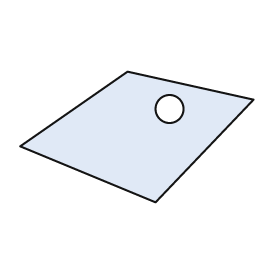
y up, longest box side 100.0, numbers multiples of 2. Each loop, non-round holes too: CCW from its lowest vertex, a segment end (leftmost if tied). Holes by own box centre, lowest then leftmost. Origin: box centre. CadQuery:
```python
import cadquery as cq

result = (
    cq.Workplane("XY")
    .moveTo(8.0, -28.0)
    .lineTo(50.0, 16.0)
    .lineTo(-4.0, 28.0)
    .lineTo(-50.0, -4.0)
    .close()
    .moveTo(14.0, 12.0)
    .circle(6.0)
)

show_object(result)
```